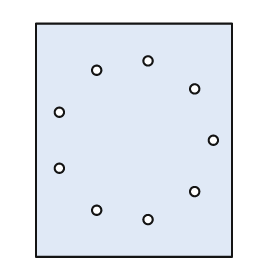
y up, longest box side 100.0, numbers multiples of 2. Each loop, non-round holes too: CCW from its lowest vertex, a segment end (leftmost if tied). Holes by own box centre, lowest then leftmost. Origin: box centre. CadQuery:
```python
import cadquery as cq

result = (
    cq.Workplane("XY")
    .moveTo(-42.0, -50.0)
    .lineTo(42.0, -50.0)
    .lineTo(42.0, 50.0)
    .lineTo(-42.0, 50.0)
    .close()
    .moveTo(6.0, -34.0)
    .circle(2.0)
    .moveTo(-16.0, -30.0)
    .circle(2.0)
    .moveTo(26.0, -22.0)
    .circle(2.0)
    .moveTo(-32.0, -12.0)
    .circle(2.0)
    .moveTo(34.0, 0.0)
    .circle(2.0)
    .moveTo(-32.0, 12.0)
    .circle(2.0)
    .moveTo(26.0, 22.0)
    .circle(2.0)
    .moveTo(-16.0, 30.0)
    .circle(2.0)
    .moveTo(6.0, 34.0)
    .circle(2.0)
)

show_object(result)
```